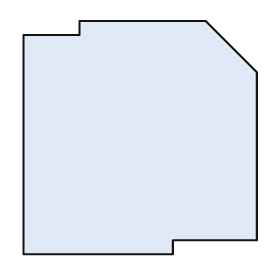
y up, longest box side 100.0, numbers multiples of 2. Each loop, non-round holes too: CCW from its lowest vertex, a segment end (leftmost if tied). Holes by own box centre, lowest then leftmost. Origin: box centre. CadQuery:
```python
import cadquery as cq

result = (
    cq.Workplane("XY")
    .moveTo(-50.0, -50.0)
    .lineTo(14.0, -50.0)
    .lineTo(14.0, -44.0)
    .lineTo(50.0, -44.0)
    .lineTo(50.0, 28.0)
    .lineTo(28.0, 50.0)
    .lineTo(-26.0, 50.0)
    .lineTo(-26.0, 44.0)
    .lineTo(-50.0, 44.0)
    .close()
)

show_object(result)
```